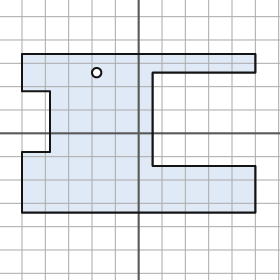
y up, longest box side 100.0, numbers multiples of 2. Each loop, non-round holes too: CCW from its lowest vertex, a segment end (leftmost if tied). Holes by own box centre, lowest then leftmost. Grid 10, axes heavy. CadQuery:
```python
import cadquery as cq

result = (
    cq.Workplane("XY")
    .moveTo(-50.0, -34.0)
    .lineTo(50.0, -34.0)
    .lineTo(50.0, -14.0)
    .lineTo(6.0, -14.0)
    .lineTo(6.0, 26.0)
    .lineTo(50.0, 26.0)
    .lineTo(50.0, 34.0)
    .lineTo(-50.0, 34.0)
    .lineTo(-50.0, 18.0)
    .lineTo(-38.0, 18.0)
    .lineTo(-38.0, -8.0)
    .lineTo(-50.0, -8.0)
    .close()
    .moveTo(-18.0, 26.0)
    .circle(2.0)
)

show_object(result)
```